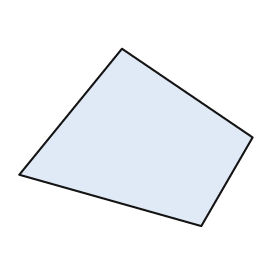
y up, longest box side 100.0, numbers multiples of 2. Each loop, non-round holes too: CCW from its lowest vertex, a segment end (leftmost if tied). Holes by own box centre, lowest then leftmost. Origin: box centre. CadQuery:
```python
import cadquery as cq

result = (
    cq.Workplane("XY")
    .moveTo(28.0, -38.0)
    .lineTo(50.0, 0.0)
    .lineTo(-6.0, 38.0)
    .lineTo(-50.0, -16.0)
    .close()
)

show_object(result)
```